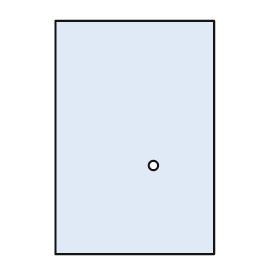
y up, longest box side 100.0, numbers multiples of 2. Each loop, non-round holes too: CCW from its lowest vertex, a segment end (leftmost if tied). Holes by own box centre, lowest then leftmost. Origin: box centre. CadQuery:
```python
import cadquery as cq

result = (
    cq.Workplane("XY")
    .moveTo(-34.0, -50.0)
    .lineTo(34.0, -50.0)
    .lineTo(34.0, 50.0)
    .lineTo(-34.0, 50.0)
    .close()
    .moveTo(8.0, -12.0)
    .circle(2.0)
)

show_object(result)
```